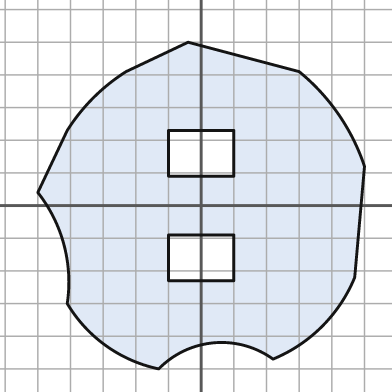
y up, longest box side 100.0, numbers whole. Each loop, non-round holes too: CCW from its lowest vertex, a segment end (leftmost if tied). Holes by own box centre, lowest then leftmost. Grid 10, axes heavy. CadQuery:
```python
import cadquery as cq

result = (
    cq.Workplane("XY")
    .moveTo(-13.0, -50.0)
    .threePointArc((4.0, -42.0), (22.0, -47.0))
    .threePointArc((37.0, -37.0), (47.0, -22.0))
    .lineTo(50.0, 12.0)
    .threePointArc((42.0, 28.0), (30.0, 41.0))
    .lineTo(-4.0, 50.0)
    .lineTo(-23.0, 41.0)
    .threePointArc((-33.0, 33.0), (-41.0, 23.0))
    .lineTo(-50.0, 4.0)
    .threePointArc((-42.0, -12.0), (-41.0, -30.0))
    .threePointArc((-29.0, -43.0), (-13.0, -50.0))
    .close()
    .moveTo(-10.0, -23.0)
    .lineTo(10.0, -23.0)
    .lineTo(10.0, -9.0)
    .lineTo(-10.0, -9.0)
    .close()
    .moveTo(-10.0, 9.0)
    .lineTo(10.0, 9.0)
    .lineTo(10.0, 23.0)
    .lineTo(-10.0, 23.0)
    .close()
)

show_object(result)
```